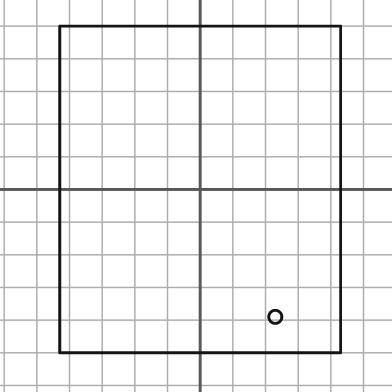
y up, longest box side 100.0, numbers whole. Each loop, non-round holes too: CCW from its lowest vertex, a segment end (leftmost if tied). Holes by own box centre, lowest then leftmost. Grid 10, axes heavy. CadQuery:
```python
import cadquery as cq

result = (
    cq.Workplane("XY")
    .moveTo(-43.0, -50.0)
    .lineTo(43.0, -50.0)
    .lineTo(43.0, 50.0)
    .lineTo(-43.0, 50.0)
    .close()
    .moveTo(23.0, -39.0)
    .circle(2.0)
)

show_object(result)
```